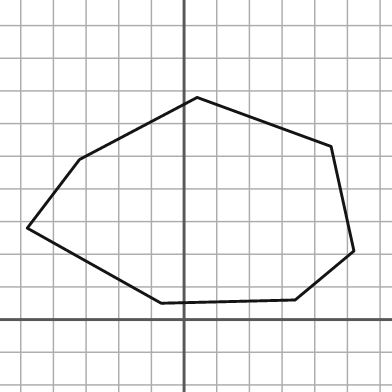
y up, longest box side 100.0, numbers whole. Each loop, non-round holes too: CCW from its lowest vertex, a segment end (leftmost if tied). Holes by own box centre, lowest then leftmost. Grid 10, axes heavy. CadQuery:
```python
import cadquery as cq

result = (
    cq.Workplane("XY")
    .moveTo(-7.0, 5.0)
    .lineTo(34.0, 6.0)
    .lineTo(52.0, 21.0)
    .lineTo(45.0, 53.0)
    .lineTo(4.0, 68.0)
    .lineTo(-32.0, 49.0)
    .lineTo(-48.0, 28.0)
    .close()
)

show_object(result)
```